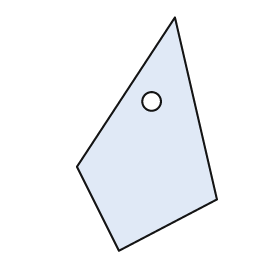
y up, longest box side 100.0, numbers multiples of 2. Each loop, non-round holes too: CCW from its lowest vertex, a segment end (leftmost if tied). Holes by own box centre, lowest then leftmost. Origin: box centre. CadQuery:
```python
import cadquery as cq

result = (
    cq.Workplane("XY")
    .moveTo(-12.0, -50.0)
    .lineTo(30.0, -28.0)
    .lineTo(12.0, 50.0)
    .lineTo(-30.0, -14.0)
    .close()
    .moveTo(2.0, 14.0)
    .circle(4.0)
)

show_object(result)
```